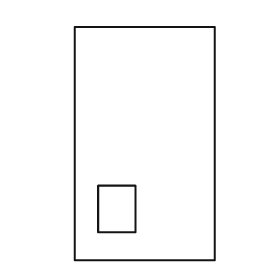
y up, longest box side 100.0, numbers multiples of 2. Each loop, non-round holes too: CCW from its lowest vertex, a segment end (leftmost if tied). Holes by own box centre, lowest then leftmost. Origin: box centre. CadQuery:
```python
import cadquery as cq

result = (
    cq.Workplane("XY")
    .moveTo(-30.0, -50.0)
    .lineTo(30.0, -50.0)
    .lineTo(30.0, 50.0)
    .lineTo(-30.0, 50.0)
    .close()
    .moveTo(-20.0, -38.0)
    .lineTo(-4.0, -38.0)
    .lineTo(-4.0, -18.0)
    .lineTo(-20.0, -18.0)
    .close()
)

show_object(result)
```